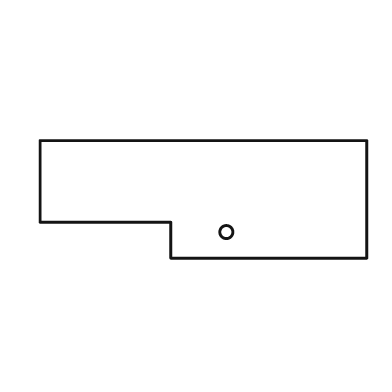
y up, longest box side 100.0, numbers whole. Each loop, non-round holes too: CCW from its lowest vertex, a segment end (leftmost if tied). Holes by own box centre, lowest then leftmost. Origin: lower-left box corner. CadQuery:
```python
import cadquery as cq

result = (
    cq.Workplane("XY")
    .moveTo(40.0, 0.0)
    .lineTo(100.0, 0.0)
    .lineTo(100.0, 36.0)
    .lineTo(0.0, 36.0)
    .lineTo(0.0, 11.0)
    .lineTo(40.0, 11.0)
    .close()
    .moveTo(57.0, 8.0)
    .circle(2.0)
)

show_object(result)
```